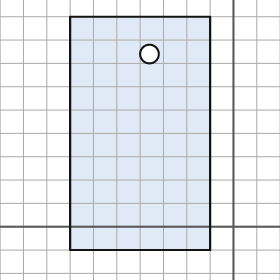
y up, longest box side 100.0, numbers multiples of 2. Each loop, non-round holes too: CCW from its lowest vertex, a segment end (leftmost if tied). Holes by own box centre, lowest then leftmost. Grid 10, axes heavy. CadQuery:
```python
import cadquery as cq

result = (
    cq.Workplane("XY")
    .moveTo(-70.0, -10.0)
    .lineTo(-10.0, -10.0)
    .lineTo(-10.0, 90.0)
    .lineTo(-70.0, 90.0)
    .close()
    .moveTo(-36.0, 74.0)
    .circle(4.0)
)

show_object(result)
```